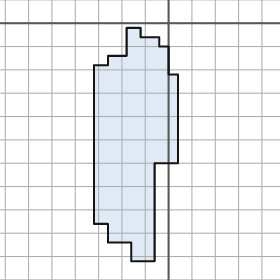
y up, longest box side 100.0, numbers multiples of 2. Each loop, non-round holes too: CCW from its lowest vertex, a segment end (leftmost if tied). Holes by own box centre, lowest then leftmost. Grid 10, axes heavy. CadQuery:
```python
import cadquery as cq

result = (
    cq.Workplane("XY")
    .moveTo(-16.0, -102.0)
    .lineTo(-6.0, -102.0)
    .lineTo(-6.0, -60.0)
    .lineTo(4.0, -60.0)
    .lineTo(4.0, -22.0)
    .lineTo(0.0, -22.0)
    .lineTo(0.0, -10.0)
    .lineTo(-4.0, -10.0)
    .lineTo(-4.0, -6.0)
    .lineTo(-12.0, -6.0)
    .lineTo(-12.0, -2.0)
    .lineTo(-18.0, -2.0)
    .lineTo(-18.0, -14.0)
    .lineTo(-26.0, -14.0)
    .lineTo(-26.0, -18.0)
    .lineTo(-32.0, -18.0)
    .lineTo(-32.0, -86.0)
    .lineTo(-26.0, -86.0)
    .lineTo(-26.0, -94.0)
    .lineTo(-16.0, -94.0)
    .close()
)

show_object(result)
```